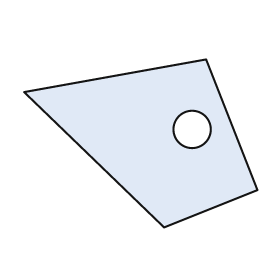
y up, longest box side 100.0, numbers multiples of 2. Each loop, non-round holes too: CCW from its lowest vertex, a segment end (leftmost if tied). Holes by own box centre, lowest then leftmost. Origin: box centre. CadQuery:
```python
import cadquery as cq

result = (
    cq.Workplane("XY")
    .moveTo(10.0, -36.0)
    .lineTo(50.0, -20.0)
    .lineTo(28.0, 36.0)
    .lineTo(-50.0, 22.0)
    .close()
    .moveTo(22.0, 6.0)
    .circle(8.0)
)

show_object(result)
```